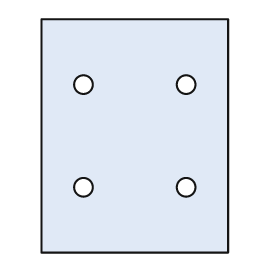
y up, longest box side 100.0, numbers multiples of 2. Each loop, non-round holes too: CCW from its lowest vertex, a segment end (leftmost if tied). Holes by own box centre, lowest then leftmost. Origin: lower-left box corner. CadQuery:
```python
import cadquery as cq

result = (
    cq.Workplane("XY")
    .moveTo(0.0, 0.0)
    .lineTo(80.0, 0.0)
    .lineTo(80.0, 100.0)
    .lineTo(0.0, 100.0)
    .close()
    .moveTo(18.0, 28.0)
    .circle(4.0)
    .moveTo(62.0, 28.0)
    .circle(4.0)
    .moveTo(18.0, 72.0)
    .circle(4.0)
    .moveTo(62.0, 72.0)
    .circle(4.0)
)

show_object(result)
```